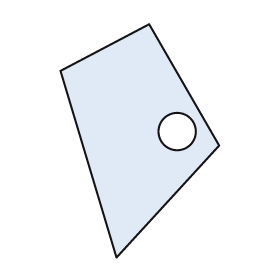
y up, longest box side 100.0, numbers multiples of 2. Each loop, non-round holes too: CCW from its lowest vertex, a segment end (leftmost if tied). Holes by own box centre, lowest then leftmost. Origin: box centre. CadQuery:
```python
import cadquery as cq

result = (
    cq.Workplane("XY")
    .moveTo(-10.0, -50.0)
    .lineTo(34.0, -2.0)
    .lineTo(4.0, 50.0)
    .lineTo(-34.0, 30.0)
    .close()
    .moveTo(16.0, 4.0)
    .circle(8.0)
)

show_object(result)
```